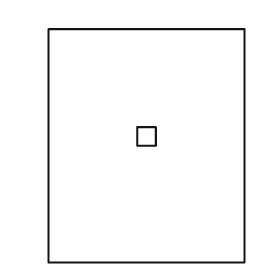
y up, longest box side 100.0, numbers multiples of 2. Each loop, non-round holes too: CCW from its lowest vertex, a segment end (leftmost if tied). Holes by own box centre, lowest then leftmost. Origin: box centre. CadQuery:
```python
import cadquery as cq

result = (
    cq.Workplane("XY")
    .moveTo(-42.0, -50.0)
    .lineTo(42.0, -50.0)
    .lineTo(42.0, 50.0)
    .lineTo(-42.0, 50.0)
    .close()
    .moveTo(-4.0, 0.0)
    .lineTo(4.0, 0.0)
    .lineTo(4.0, 8.0)
    .lineTo(-4.0, 8.0)
    .close()
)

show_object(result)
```